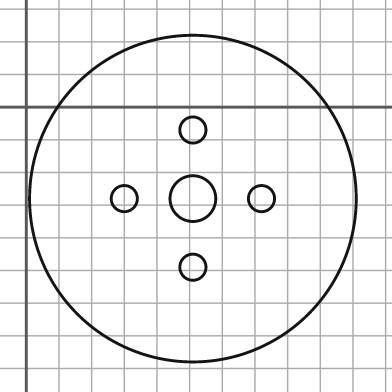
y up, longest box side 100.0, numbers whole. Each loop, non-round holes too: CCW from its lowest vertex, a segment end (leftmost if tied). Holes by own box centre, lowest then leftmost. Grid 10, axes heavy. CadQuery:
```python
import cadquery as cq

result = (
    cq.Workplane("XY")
    .moveTo(51.0, -28.0)
    .circle(50.0)
    .moveTo(51.0, -49.0)
    .circle(4.0)
    .moveTo(30.0, -28.0)
    .circle(4.0)
    .moveTo(51.0, -28.0)
    .circle(7.0)
    .moveTo(72.0, -28.0)
    .circle(4.0)
    .moveTo(51.0, -7.0)
    .circle(4.0)
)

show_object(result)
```